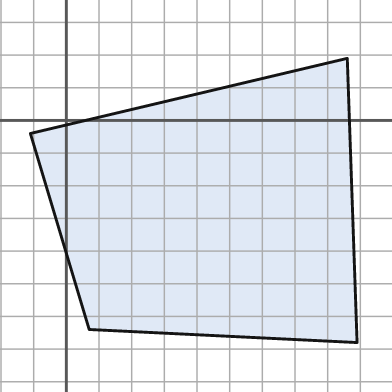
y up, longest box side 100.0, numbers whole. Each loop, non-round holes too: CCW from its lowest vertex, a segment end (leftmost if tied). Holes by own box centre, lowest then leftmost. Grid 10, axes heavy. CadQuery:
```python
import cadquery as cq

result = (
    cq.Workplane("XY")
    .moveTo(89.0, -68.0)
    .lineTo(86.0, 19.0)
    .lineTo(-11.0, -4.0)
    .lineTo(7.0, -64.0)
    .close()
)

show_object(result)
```